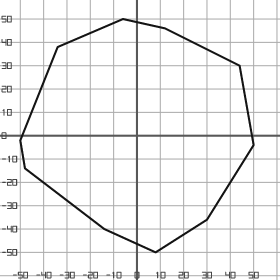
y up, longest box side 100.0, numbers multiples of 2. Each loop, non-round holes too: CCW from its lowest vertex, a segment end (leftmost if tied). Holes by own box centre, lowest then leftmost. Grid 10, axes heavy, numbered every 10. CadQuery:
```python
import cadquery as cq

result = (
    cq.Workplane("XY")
    .moveTo(8.0, -50.0)
    .lineTo(30.0, -36.0)
    .lineTo(50.0, -4.0)
    .lineTo(44.0, 30.0)
    .lineTo(12.0, 46.0)
    .lineTo(-6.0, 50.0)
    .lineTo(-34.0, 38.0)
    .lineTo(-50.0, -2.0)
    .lineTo(-48.0, -14.0)
    .lineTo(-14.0, -40.0)
    .close()
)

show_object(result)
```